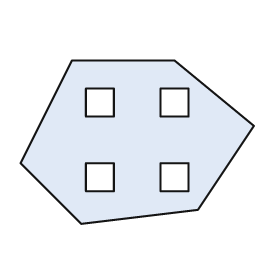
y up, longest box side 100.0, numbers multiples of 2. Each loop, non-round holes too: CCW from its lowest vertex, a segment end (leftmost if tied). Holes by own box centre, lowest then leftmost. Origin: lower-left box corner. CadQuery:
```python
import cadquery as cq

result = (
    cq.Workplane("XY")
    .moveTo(26.0, 0.0)
    .lineTo(76.0, 6.0)
    .lineTo(100.0, 42.0)
    .lineTo(66.0, 70.0)
    .lineTo(22.0, 70.0)
    .lineTo(0.0, 26.0)
    .close()
    .moveTo(28.0, 14.0)
    .lineTo(40.0, 14.0)
    .lineTo(40.0, 26.0)
    .lineTo(28.0, 26.0)
    .close()
    .moveTo(60.0, 14.0)
    .lineTo(72.0, 14.0)
    .lineTo(72.0, 26.0)
    .lineTo(60.0, 26.0)
    .close()
    .moveTo(28.0, 46.0)
    .lineTo(40.0, 46.0)
    .lineTo(40.0, 58.0)
    .lineTo(28.0, 58.0)
    .close()
    .moveTo(60.0, 46.0)
    .lineTo(72.0, 46.0)
    .lineTo(72.0, 58.0)
    .lineTo(60.0, 58.0)
    .close()
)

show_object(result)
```